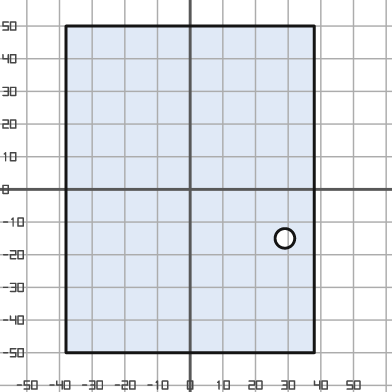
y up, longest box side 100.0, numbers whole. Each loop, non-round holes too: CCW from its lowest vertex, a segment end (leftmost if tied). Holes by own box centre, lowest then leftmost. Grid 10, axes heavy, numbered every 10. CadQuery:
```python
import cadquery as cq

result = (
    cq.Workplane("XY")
    .moveTo(-38.0, -50.0)
    .lineTo(38.0, -50.0)
    .lineTo(38.0, 50.0)
    .lineTo(-38.0, 50.0)
    .close()
    .moveTo(29.0, -15.0)
    .circle(3.0)
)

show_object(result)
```